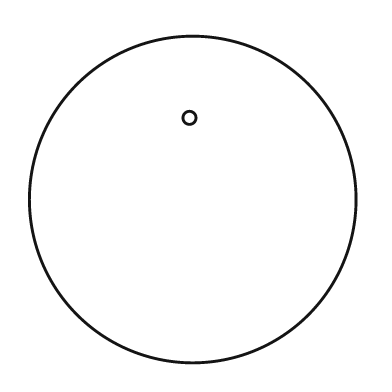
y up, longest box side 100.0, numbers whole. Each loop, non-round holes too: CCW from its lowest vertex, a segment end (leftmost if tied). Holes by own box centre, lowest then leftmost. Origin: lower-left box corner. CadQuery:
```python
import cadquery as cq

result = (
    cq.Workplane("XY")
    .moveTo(50.0, 50.0)
    .circle(50.0)
    .moveTo(49.0, 75.0)
    .circle(2.0)
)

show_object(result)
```